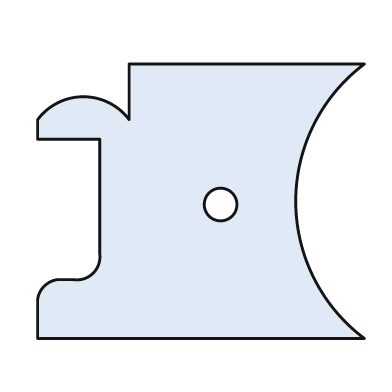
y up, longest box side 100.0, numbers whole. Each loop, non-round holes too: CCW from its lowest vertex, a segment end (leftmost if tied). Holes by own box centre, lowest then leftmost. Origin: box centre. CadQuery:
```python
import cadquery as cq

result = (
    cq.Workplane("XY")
    .moveTo(-50.0, -42.0)
    .lineTo(50.0, -42.0)
    .threePointArc((29.0, 0.0), (50.0, 42.0))
    .lineTo(-22.0, 42.0)
    .lineTo(-22.0, 25.0)
    .threePointArc((-36.0, 32.0), (-50.0, 25.0))
    .lineTo(-50.0, 19.0)
    .lineTo(-31.0, 19.0)
    .lineTo(-31.0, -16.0)
    .threePointArc((-33.0, -22.0), (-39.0, -24.0))
    .lineTo(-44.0, -24.0)
    .threePointArc((-48.0, -26.0), (-50.0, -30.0))
    .close()
    .moveTo(6.0, -1.0)
    .circle(5.0)
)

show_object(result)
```